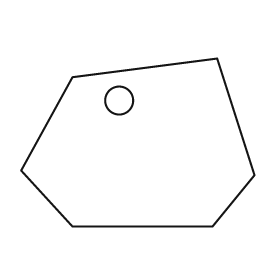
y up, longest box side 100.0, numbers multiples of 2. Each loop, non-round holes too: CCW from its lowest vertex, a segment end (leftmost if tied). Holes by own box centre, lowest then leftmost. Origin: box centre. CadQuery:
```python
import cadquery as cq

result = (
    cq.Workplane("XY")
    .moveTo(-28.0, -36.0)
    .lineTo(32.0, -36.0)
    .lineTo(50.0, -14.0)
    .lineTo(34.0, 36.0)
    .lineTo(-28.0, 28.0)
    .lineTo(-50.0, -12.0)
    .close()
    .moveTo(-8.0, 18.0)
    .circle(6.0)
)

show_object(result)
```